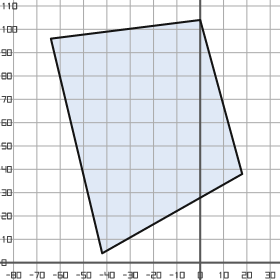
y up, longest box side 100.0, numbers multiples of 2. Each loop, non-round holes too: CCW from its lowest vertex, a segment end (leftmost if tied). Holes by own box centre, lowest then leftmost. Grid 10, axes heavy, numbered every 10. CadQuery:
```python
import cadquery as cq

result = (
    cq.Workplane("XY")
    .moveTo(-42.0, 4.0)
    .lineTo(18.0, 38.0)
    .lineTo(0.0, 104.0)
    .lineTo(-64.0, 96.0)
    .close()
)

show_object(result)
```